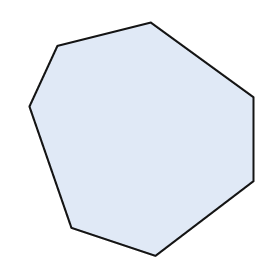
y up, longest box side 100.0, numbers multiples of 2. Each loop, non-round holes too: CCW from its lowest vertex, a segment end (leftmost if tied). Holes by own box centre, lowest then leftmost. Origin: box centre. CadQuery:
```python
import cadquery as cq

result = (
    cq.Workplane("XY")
    .moveTo(6.0, -50.0)
    .lineTo(48.0, -18.0)
    .lineTo(48.0, 18.0)
    .lineTo(4.0, 50.0)
    .lineTo(-36.0, 40.0)
    .lineTo(-48.0, 14.0)
    .lineTo(-30.0, -38.0)
    .close()
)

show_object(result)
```